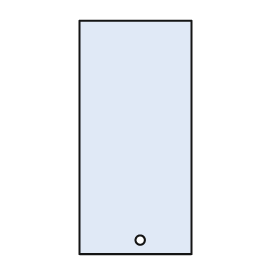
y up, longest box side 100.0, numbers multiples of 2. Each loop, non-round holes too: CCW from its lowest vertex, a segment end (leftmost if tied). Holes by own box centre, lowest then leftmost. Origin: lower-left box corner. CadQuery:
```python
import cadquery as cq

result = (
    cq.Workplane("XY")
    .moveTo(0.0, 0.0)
    .lineTo(48.0, 0.0)
    .lineTo(48.0, 100.0)
    .lineTo(0.0, 100.0)
    .close()
    .moveTo(26.0, 6.0)
    .circle(2.0)
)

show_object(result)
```